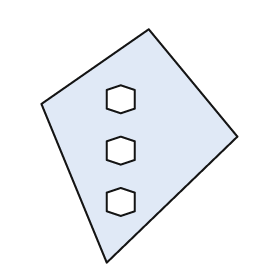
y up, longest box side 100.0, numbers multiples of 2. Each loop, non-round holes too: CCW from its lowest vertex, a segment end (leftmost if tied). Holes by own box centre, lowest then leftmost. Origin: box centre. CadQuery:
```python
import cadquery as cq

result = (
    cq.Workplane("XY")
    .moveTo(-14.0, -50.0)
    .lineTo(42.0, 4.0)
    .lineTo(4.0, 50.0)
    .lineTo(-42.0, 18.0)
    .close()
    .moveTo(-8.0, -30.0)
    .lineTo(-2.0, -28.0)
    .lineTo(-2.0, -20.0)
    .lineTo(-8.0, -18.0)
    .lineTo(-14.0, -20.0)
    .lineTo(-14.0, -28.0)
    .close()
    .moveTo(-8.0, -8.0)
    .lineTo(-2.0, -6.0)
    .lineTo(-2.0, 2.0)
    .lineTo(-8.0, 4.0)
    .lineTo(-14.0, 2.0)
    .lineTo(-14.0, -6.0)
    .close()
    .moveTo(-8.0, 14.0)
    .lineTo(-2.0, 16.0)
    .lineTo(-2.0, 24.0)
    .lineTo(-8.0, 26.0)
    .lineTo(-14.0, 24.0)
    .lineTo(-14.0, 16.0)
    .close()
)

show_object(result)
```